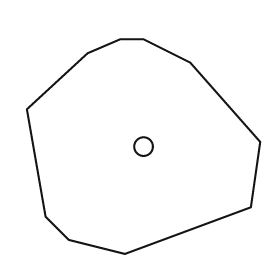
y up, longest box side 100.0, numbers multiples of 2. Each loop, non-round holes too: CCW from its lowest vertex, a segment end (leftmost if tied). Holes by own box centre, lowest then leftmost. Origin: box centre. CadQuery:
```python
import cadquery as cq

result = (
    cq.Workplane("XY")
    .moveTo(-8.0, -46.0)
    .lineTo(46.0, -26.0)
    .lineTo(50.0, 2.0)
    .lineTo(20.0, 36.0)
    .lineTo(0.0, 46.0)
    .lineTo(-10.0, 46.0)
    .lineTo(-24.0, 40.0)
    .lineTo(-50.0, 16.0)
    .lineTo(-42.0, -30.0)
    .lineTo(-32.0, -40.0)
    .close()
    .moveTo(0.0, 0.0)
    .circle(4.0)
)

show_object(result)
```